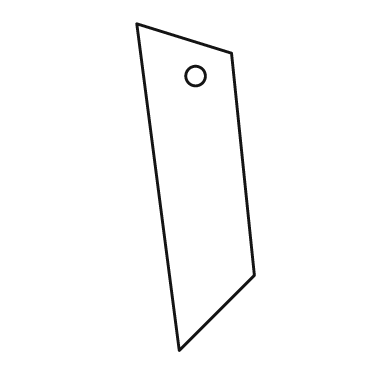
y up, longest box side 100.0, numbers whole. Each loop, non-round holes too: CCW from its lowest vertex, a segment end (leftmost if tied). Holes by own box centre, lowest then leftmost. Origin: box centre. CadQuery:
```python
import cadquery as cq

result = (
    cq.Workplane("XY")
    .moveTo(-5.0, -50.0)
    .lineTo(18.0, -27.0)
    .lineTo(11.0, 41.0)
    .lineTo(-18.0, 50.0)
    .close()
    .moveTo(0.0, 34.0)
    .circle(3.0)
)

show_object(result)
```